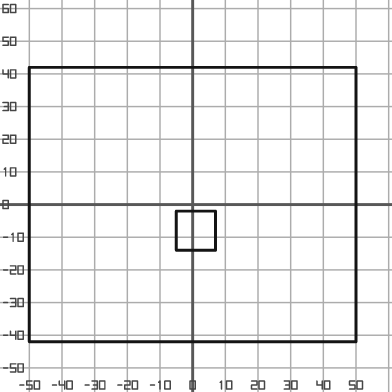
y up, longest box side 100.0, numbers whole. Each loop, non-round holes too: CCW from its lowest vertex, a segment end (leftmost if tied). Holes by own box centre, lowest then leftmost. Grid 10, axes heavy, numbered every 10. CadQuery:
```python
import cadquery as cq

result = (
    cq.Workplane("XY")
    .moveTo(-50.0, -42.0)
    .lineTo(50.0, -42.0)
    .lineTo(50.0, 42.0)
    .lineTo(-50.0, 42.0)
    .close()
    .moveTo(-5.0, -14.0)
    .lineTo(7.0, -14.0)
    .lineTo(7.0, -2.0)
    .lineTo(-5.0, -2.0)
    .close()
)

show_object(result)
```